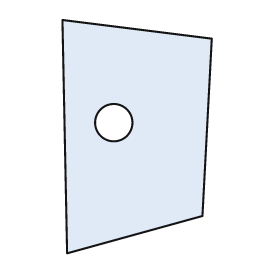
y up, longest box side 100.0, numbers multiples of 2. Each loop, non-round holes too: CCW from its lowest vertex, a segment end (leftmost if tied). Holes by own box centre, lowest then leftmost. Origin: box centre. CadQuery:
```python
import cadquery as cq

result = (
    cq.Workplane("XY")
    .moveTo(-30.0, -50.0)
    .lineTo(28.0, -34.0)
    .lineTo(32.0, 42.0)
    .lineTo(-32.0, 50.0)
    .close()
    .moveTo(-10.0, 6.0)
    .circle(8.0)
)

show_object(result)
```